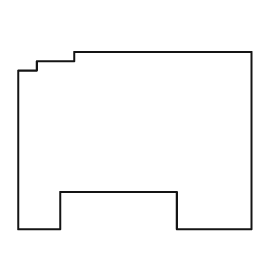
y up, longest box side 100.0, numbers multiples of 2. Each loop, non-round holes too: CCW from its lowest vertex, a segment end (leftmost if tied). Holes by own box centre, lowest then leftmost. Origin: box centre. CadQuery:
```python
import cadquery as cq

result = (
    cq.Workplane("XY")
    .moveTo(-50.0, -38.0)
    .lineTo(-32.0, -38.0)
    .lineTo(-32.0, -22.0)
    .lineTo(18.0, -22.0)
    .lineTo(18.0, -38.0)
    .lineTo(50.0, -38.0)
    .lineTo(50.0, 38.0)
    .lineTo(-26.0, 38.0)
    .lineTo(-26.0, 34.0)
    .lineTo(-42.0, 34.0)
    .lineTo(-42.0, 30.0)
    .lineTo(-50.0, 30.0)
    .close()
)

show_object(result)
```